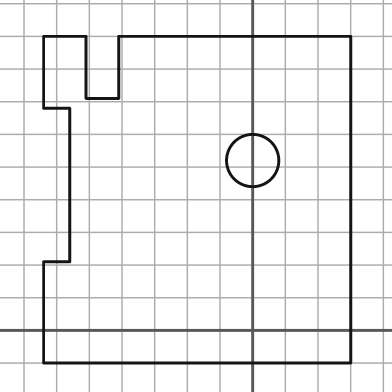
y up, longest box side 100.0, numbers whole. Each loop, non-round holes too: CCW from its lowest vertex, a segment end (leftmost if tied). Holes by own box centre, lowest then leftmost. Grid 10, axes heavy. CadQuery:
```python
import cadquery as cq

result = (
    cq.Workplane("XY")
    .moveTo(-64.0, -10.0)
    .lineTo(30.0, -10.0)
    .lineTo(30.0, 90.0)
    .lineTo(-41.0, 90.0)
    .lineTo(-41.0, 71.0)
    .lineTo(-51.0, 71.0)
    .lineTo(-51.0, 90.0)
    .lineTo(-64.0, 90.0)
    .lineTo(-64.0, 68.0)
    .lineTo(-56.0, 68.0)
    .lineTo(-56.0, 21.0)
    .lineTo(-64.0, 21.0)
    .close()
    .moveTo(0.0, 52.0)
    .circle(8.0)
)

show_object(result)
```